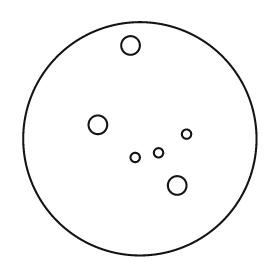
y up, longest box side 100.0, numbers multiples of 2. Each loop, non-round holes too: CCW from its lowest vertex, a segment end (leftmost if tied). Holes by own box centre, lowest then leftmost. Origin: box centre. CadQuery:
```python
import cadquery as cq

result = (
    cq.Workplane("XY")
    .moveTo(0.0, 0.0)
    .circle(50.0)
    .moveTo(16.0, -20.0)
    .circle(4.0)
    .moveTo(-2.0, -8.0)
    .circle(2.0)
    .moveTo(8.0, -6.0)
    .circle(2.0)
    .moveTo(20.0, 2.0)
    .circle(2.0)
    .moveTo(-18.0, 6.0)
    .circle(4.0)
    .moveTo(-4.0, 40.0)
    .circle(4.0)
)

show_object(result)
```